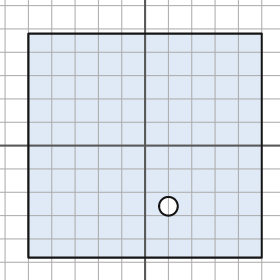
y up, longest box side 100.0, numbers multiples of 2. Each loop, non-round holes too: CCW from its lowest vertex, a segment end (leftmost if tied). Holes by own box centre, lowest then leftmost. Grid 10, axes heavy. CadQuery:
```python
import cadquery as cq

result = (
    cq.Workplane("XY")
    .moveTo(-50.0, -48.0)
    .lineTo(50.0, -48.0)
    .lineTo(50.0, 48.0)
    .lineTo(-50.0, 48.0)
    .close()
    .moveTo(10.0, -26.0)
    .circle(4.0)
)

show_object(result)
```